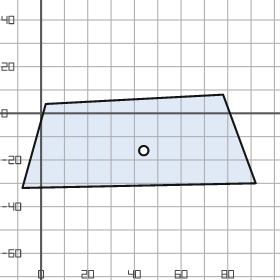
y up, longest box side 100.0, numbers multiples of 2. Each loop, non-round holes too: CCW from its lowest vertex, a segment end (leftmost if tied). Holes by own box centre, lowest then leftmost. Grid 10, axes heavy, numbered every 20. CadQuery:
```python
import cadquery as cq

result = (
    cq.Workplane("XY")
    .moveTo(-8.0, -32.0)
    .lineTo(92.0, -30.0)
    .lineTo(78.0, 8.0)
    .lineTo(2.0, 4.0)
    .close()
    .moveTo(44.0, -16.0)
    .circle(2.0)
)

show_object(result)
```